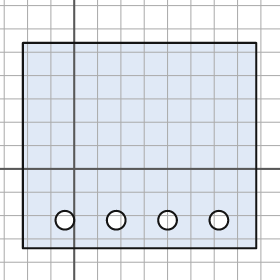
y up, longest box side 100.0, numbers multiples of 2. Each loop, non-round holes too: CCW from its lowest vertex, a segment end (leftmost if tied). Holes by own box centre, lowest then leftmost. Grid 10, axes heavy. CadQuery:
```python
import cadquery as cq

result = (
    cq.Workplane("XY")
    .moveTo(-22.0, -34.0)
    .lineTo(78.0, -34.0)
    .lineTo(78.0, 54.0)
    .lineTo(-22.0, 54.0)
    .close()
    .moveTo(-4.0, -22.0)
    .circle(4.0)
    .moveTo(18.0, -22.0)
    .circle(4.0)
    .moveTo(40.0, -22.0)
    .circle(4.0)
    .moveTo(62.0, -22.0)
    .circle(4.0)
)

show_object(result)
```